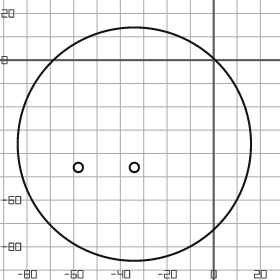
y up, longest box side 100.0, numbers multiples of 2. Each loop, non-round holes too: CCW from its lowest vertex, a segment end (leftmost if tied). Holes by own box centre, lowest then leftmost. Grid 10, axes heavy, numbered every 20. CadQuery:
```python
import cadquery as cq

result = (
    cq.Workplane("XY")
    .moveTo(-34.0, -36.0)
    .circle(50.0)
    .moveTo(-58.0, -46.0)
    .circle(2.0)
    .moveTo(-34.0, -46.0)
    .circle(2.0)
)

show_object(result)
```